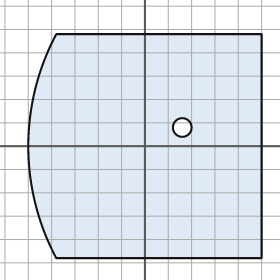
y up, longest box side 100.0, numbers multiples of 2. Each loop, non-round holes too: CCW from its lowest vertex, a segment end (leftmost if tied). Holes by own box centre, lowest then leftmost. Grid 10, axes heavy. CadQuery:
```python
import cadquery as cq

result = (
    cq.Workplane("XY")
    .moveTo(-38.0, -48.0)
    .lineTo(50.0, -48.0)
    .lineTo(50.0, 48.0)
    .lineTo(-38.0, 48.0)
    .threePointArc((-50.0, 0.0), (-38.0, -48.0))
    .close()
    .moveTo(16.0, 8.0)
    .circle(4.0)
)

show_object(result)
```